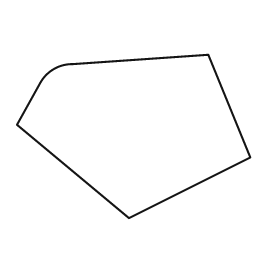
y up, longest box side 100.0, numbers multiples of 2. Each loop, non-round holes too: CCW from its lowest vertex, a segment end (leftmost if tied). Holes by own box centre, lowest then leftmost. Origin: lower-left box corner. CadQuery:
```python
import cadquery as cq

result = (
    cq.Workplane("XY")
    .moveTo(48.0, 0.0)
    .lineTo(100.0, 26.0)
    .lineTo(82.0, 70.0)
    .lineTo(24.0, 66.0)
    .threePointArc((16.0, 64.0), (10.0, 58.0))
    .lineTo(0.0, 40.0)
    .close()
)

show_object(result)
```